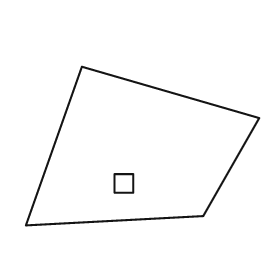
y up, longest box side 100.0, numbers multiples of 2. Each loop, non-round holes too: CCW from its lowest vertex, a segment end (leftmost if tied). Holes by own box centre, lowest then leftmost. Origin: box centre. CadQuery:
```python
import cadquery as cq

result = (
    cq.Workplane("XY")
    .moveTo(-50.0, -34.0)
    .lineTo(26.0, -30.0)
    .lineTo(50.0, 12.0)
    .lineTo(-26.0, 34.0)
    .close()
    .moveTo(-12.0, -20.0)
    .lineTo(-4.0, -20.0)
    .lineTo(-4.0, -12.0)
    .lineTo(-12.0, -12.0)
    .close()
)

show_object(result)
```